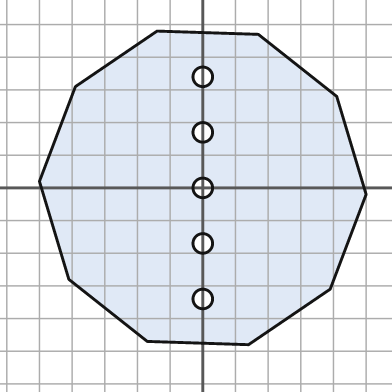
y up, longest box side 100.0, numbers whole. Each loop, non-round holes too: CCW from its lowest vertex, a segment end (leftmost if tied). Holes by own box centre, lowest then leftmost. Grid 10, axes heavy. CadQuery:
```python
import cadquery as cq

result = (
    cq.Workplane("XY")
    .moveTo(14.0, -48.0)
    .lineTo(39.0, -31.0)
    .lineTo(50.0, -2.0)
    .lineTo(41.0, 28.0)
    .lineTo(17.0, 47.0)
    .lineTo(-14.0, 48.0)
    .lineTo(-39.0, 31.0)
    .lineTo(-50.0, 2.0)
    .lineTo(-41.0, -28.0)
    .lineTo(-17.0, -47.0)
    .close()
    .moveTo(0.0, -34.0)
    .circle(3.0)
    .moveTo(0.0, -17.0)
    .circle(3.0)
    .moveTo(0.0, 0.0)
    .circle(3.0)
    .moveTo(0.0, 17.0)
    .circle(3.0)
    .moveTo(0.0, 34.0)
    .circle(3.0)
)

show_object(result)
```